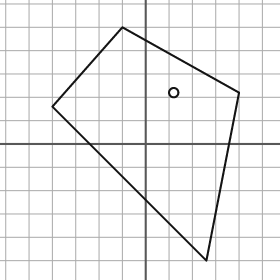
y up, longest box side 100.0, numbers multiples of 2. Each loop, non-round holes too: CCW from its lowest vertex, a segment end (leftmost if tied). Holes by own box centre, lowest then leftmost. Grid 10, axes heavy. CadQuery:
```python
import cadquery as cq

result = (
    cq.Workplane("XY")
    .moveTo(26.0, -50.0)
    .lineTo(40.0, 22.0)
    .lineTo(-10.0, 50.0)
    .lineTo(-40.0, 16.0)
    .close()
    .moveTo(12.0, 22.0)
    .circle(2.0)
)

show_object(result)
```